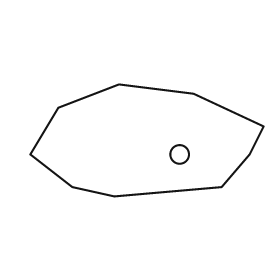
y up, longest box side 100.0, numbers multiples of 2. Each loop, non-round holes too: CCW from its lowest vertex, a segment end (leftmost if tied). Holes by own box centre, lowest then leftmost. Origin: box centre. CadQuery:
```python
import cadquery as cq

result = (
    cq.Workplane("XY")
    .moveTo(-14.0, -24.0)
    .lineTo(32.0, -20.0)
    .lineTo(44.0, -6.0)
    .lineTo(50.0, 6.0)
    .lineTo(20.0, 20.0)
    .lineTo(-12.0, 24.0)
    .lineTo(-38.0, 14.0)
    .lineTo(-50.0, -6.0)
    .lineTo(-32.0, -20.0)
    .close()
    .moveTo(14.0, -6.0)
    .circle(4.0)
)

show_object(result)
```